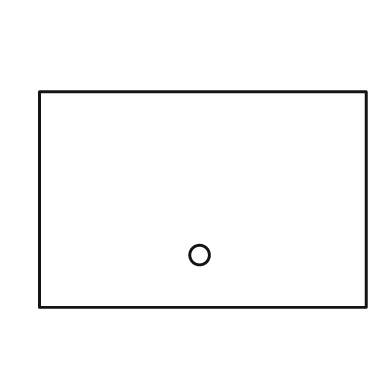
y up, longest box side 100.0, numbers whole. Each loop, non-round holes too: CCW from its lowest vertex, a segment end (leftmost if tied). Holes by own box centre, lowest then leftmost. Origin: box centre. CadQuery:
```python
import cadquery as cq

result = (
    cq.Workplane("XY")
    .moveTo(-50.0, -33.0)
    .lineTo(50.0, -33.0)
    .lineTo(50.0, 33.0)
    .lineTo(-50.0, 33.0)
    .close()
    .moveTo(-1.0, -17.0)
    .circle(3.0)
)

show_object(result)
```